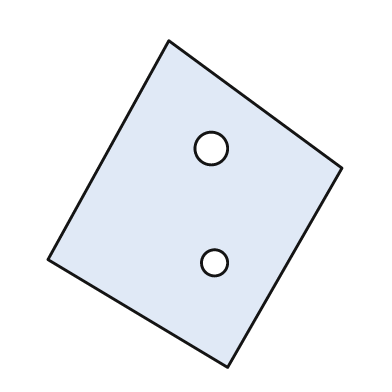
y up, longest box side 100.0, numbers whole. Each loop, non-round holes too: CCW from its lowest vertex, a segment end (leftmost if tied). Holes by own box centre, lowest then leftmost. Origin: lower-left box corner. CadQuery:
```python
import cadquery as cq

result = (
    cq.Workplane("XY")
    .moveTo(55.0, 0.0)
    .lineTo(90.0, 61.0)
    .lineTo(37.0, 100.0)
    .lineTo(0.0, 33.0)
    .close()
    .moveTo(51.0, 32.0)
    .circle(4.0)
    .moveTo(50.0, 67.0)
    .circle(5.0)
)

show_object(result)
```